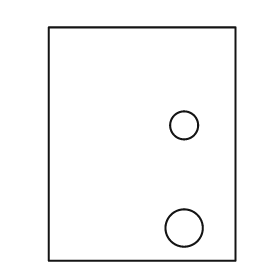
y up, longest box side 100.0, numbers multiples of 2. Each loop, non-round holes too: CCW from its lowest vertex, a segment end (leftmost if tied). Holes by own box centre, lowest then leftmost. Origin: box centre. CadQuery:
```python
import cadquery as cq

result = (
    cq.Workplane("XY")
    .moveTo(-40.0, -50.0)
    .lineTo(40.0, -50.0)
    .lineTo(40.0, 50.0)
    .lineTo(-40.0, 50.0)
    .close()
    .moveTo(18.0, -36.0)
    .circle(8.0)
    .moveTo(18.0, 8.0)
    .circle(6.0)
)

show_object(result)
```